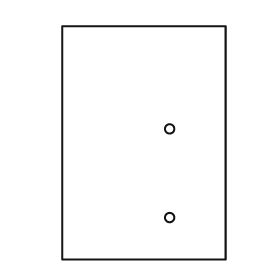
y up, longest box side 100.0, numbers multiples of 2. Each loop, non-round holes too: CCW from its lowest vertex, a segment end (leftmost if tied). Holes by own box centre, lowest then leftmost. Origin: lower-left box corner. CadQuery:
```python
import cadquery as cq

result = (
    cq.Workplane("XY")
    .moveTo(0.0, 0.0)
    .lineTo(70.0, 0.0)
    .lineTo(70.0, 100.0)
    .lineTo(0.0, 100.0)
    .close()
    .moveTo(46.0, 18.0)
    .circle(2.0)
    .moveTo(46.0, 56.0)
    .circle(2.0)
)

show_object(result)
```